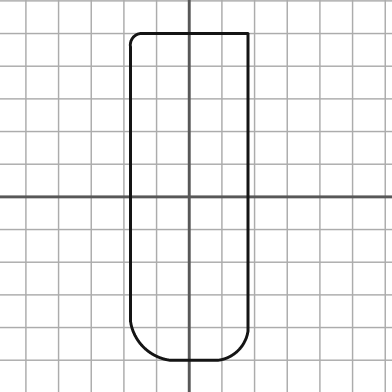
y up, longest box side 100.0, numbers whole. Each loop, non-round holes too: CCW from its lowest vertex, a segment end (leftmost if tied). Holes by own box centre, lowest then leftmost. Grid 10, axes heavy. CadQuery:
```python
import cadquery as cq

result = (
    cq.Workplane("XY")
    .moveTo(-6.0, -50.0)
    .lineTo(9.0, -50.0)
    .threePointArc((15.0, -47.0), (18.0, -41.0))
    .lineTo(18.0, 50.0)
    .lineTo(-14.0, 50.0)
    .threePointArc((-17.0, 49.0), (-18.0, 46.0))
    .lineTo(-18.0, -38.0)
    .threePointArc((-14.0, -46.0), (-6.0, -50.0))
    .close()
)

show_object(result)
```